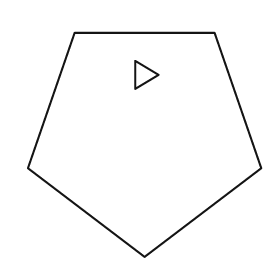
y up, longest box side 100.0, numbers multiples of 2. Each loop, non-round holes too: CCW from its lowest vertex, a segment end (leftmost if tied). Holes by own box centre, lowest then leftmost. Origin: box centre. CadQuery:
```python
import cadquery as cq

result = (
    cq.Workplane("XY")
    .moveTo(0.0, -48.0)
    .lineTo(50.0, -10.0)
    .lineTo(30.0, 48.0)
    .lineTo(-30.0, 48.0)
    .lineTo(-50.0, -10.0)
    .close()
    .moveTo(-4.0, 24.0)
    .lineTo(6.0, 30.0)
    .lineTo(-4.0, 36.0)
    .close()
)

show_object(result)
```